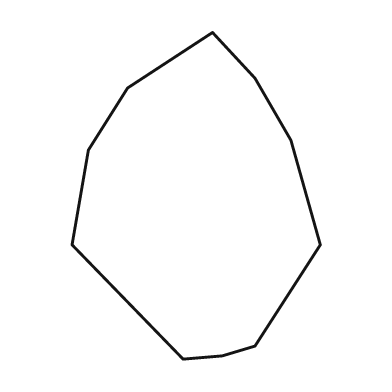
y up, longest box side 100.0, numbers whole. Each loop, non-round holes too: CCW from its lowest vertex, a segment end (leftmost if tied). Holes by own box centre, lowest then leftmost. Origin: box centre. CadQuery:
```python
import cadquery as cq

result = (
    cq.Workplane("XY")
    .moveTo(-4.0, -50.0)
    .lineTo(8.0, -49.0)
    .lineTo(18.0, -46.0)
    .lineTo(38.0, -15.0)
    .lineTo(29.0, 17.0)
    .lineTo(18.0, 36.0)
    .lineTo(5.0, 50.0)
    .lineTo(-21.0, 33.0)
    .lineTo(-33.0, 14.0)
    .lineTo(-38.0, -15.0)
    .close()
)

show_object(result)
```